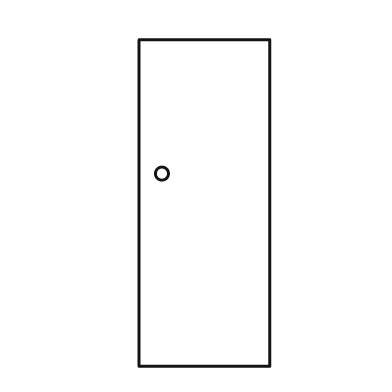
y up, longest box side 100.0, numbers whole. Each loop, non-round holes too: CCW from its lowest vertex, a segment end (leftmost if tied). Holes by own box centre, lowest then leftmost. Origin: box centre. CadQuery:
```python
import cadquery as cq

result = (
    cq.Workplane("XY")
    .moveTo(-20.0, -50.0)
    .lineTo(20.0, -50.0)
    .lineTo(20.0, 50.0)
    .lineTo(-20.0, 50.0)
    .close()
    .moveTo(-13.0, 9.0)
    .circle(2.0)
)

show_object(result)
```